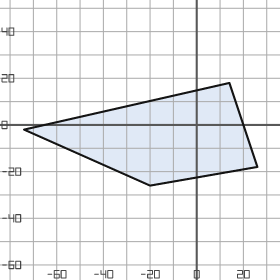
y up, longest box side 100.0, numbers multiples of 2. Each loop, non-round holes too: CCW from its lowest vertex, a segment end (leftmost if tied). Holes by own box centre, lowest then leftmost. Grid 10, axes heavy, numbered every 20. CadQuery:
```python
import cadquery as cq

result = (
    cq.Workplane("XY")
    .moveTo(-20.0, -26.0)
    .lineTo(26.0, -18.0)
    .lineTo(14.0, 18.0)
    .lineTo(-74.0, -2.0)
    .close()
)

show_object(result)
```